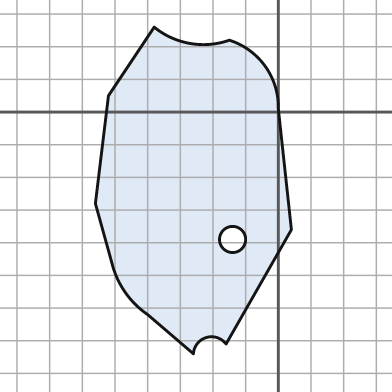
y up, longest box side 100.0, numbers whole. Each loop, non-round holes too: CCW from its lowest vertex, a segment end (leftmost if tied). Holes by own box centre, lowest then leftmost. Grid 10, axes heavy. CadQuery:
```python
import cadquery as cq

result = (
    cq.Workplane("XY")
    .moveTo(-26.0, -74.0)
    .threePointArc((-22.0, -69.0), (-16.0, -71.0))
    .lineTo(4.0, -36.0)
    .lineTo(0.0, 1.0)
    .threePointArc((-4.0, 14.0), (-15.0, 22.0))
    .threePointArc((-27.0, 21.0), (-38.0, 26.0))
    .lineTo(-52.0, 5.0)
    .lineTo(-56.0, -28.0)
    .lineTo(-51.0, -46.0)
    .threePointArc((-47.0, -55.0), (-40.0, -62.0))
    .close()
    .moveTo(-14.0, -39.0)
    .circle(4.0)
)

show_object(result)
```